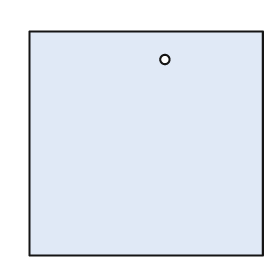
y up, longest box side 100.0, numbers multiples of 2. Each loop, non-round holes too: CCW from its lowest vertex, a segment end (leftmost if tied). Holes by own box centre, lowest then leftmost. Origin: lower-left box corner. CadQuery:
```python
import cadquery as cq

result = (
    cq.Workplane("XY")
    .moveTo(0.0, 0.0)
    .lineTo(100.0, 0.0)
    .lineTo(100.0, 96.0)
    .lineTo(0.0, 96.0)
    .close()
    .moveTo(58.0, 84.0)
    .circle(2.0)
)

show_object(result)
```